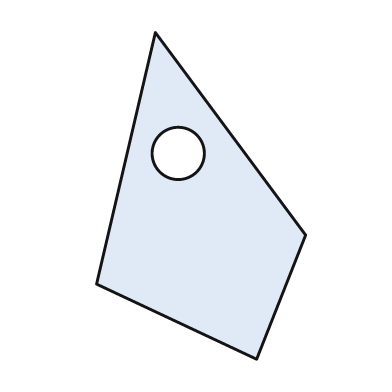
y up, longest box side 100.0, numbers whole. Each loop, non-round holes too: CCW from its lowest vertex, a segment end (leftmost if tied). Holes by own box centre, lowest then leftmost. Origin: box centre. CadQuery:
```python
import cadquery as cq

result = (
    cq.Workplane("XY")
    .moveTo(17.0, -50.0)
    .lineTo(32.0, -12.0)
    .lineTo(-14.0, 50.0)
    .lineTo(-32.0, -27.0)
    .close()
    .moveTo(-7.0, 13.0)
    .circle(8.0)
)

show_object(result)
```